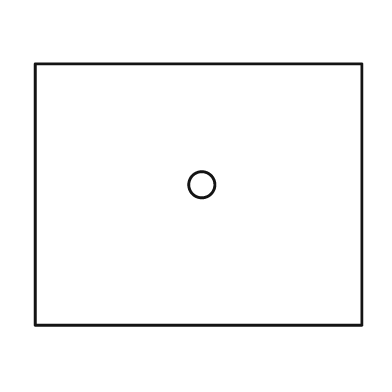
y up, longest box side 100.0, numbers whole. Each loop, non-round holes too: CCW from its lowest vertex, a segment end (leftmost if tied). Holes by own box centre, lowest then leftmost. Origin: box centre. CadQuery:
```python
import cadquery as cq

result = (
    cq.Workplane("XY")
    .moveTo(-50.0, -40.0)
    .lineTo(50.0, -40.0)
    .lineTo(50.0, 40.0)
    .lineTo(-50.0, 40.0)
    .close()
    .moveTo(1.0, 3.0)
    .circle(4.0)
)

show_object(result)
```